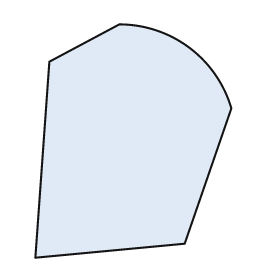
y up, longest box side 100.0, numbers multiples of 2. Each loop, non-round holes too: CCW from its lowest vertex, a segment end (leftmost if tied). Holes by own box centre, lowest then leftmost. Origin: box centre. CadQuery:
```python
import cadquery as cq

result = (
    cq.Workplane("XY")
    .moveTo(-42.0, -50.0)
    .lineTo(22.0, -44.0)
    .lineTo(42.0, 14.0)
    .threePointArc((24.0, 40.0), (-6.0, 50.0))
    .lineTo(-36.0, 34.0)
    .close()
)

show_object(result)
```